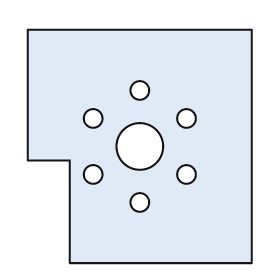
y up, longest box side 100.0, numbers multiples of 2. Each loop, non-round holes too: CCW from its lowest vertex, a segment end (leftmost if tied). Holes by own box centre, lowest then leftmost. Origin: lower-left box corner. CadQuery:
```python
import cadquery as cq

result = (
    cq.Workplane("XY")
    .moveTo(18.0, 0.0)
    .lineTo(96.0, 0.0)
    .lineTo(96.0, 100.0)
    .lineTo(0.0, 100.0)
    .lineTo(0.0, 44.0)
    .lineTo(18.0, 44.0)
    .close()
    .moveTo(48.0, 26.0)
    .circle(4.0)
    .moveTo(28.0, 38.0)
    .circle(4.0)
    .moveTo(68.0, 38.0)
    .circle(4.0)
    .moveTo(48.0, 50.0)
    .circle(10.0)
    .moveTo(28.0, 62.0)
    .circle(4.0)
    .moveTo(68.0, 62.0)
    .circle(4.0)
    .moveTo(48.0, 74.0)
    .circle(4.0)
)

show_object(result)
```